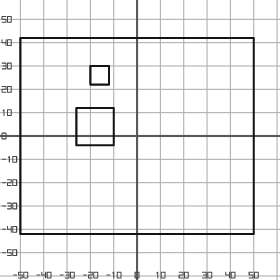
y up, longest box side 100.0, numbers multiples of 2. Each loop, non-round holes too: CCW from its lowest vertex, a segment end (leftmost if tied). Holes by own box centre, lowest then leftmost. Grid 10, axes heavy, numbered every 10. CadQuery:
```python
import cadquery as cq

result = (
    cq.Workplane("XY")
    .moveTo(-50.0, -42.0)
    .lineTo(50.0, -42.0)
    .lineTo(50.0, 42.0)
    .lineTo(-50.0, 42.0)
    .close()
    .moveTo(-26.0, -4.0)
    .lineTo(-10.0, -4.0)
    .lineTo(-10.0, 12.0)
    .lineTo(-26.0, 12.0)
    .close()
    .moveTo(-20.0, 22.0)
    .lineTo(-12.0, 22.0)
    .lineTo(-12.0, 30.0)
    .lineTo(-20.0, 30.0)
    .close()
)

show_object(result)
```